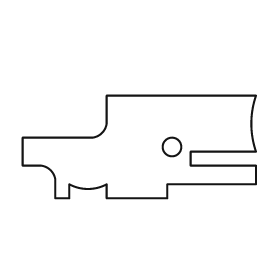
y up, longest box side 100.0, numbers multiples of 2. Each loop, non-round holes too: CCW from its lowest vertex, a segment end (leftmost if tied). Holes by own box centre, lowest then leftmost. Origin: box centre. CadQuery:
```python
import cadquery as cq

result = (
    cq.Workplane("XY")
    .moveTo(-36.0, -22.0)
    .lineTo(-30.0, -22.0)
    .lineTo(-30.0, -16.0)
    .threePointArc((-22.0, -18.0), (-14.0, -16.0))
    .lineTo(-14.0, -22.0)
    .lineTo(12.0, -22.0)
    .lineTo(12.0, -16.0)
    .lineTo(50.0, -16.0)
    .lineTo(50.0, -8.0)
    .lineTo(22.0, -8.0)
    .lineTo(22.0, -2.0)
    .lineTo(50.0, -2.0)
    .threePointArc((48.0, 10.0), (50.0, 22.0))
    .lineTo(-14.0, 22.0)
    .lineTo(-14.0, 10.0)
    .threePointArc((-16.0, 6.0), (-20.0, 4.0))
    .lineTo(-50.0, 4.0)
    .lineTo(-50.0, -8.0)
    .lineTo(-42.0, -8.0)
    .threePointArc((-38.0, -10.0), (-36.0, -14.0))
    .close()
    .moveTo(14.0, 0.0)
    .circle(4.0)
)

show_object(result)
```